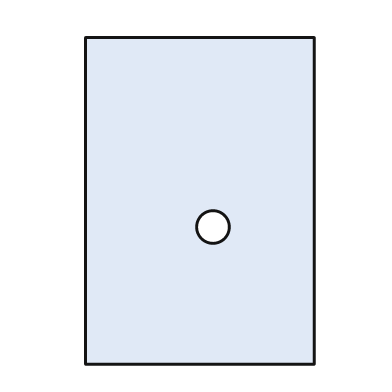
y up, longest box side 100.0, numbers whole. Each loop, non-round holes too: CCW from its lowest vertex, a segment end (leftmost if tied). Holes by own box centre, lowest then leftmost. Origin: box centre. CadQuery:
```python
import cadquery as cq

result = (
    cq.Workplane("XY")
    .moveTo(-35.0, -50.0)
    .lineTo(35.0, -50.0)
    .lineTo(35.0, 50.0)
    .lineTo(-35.0, 50.0)
    .close()
    .moveTo(4.0, -8.0)
    .circle(5.0)
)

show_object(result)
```